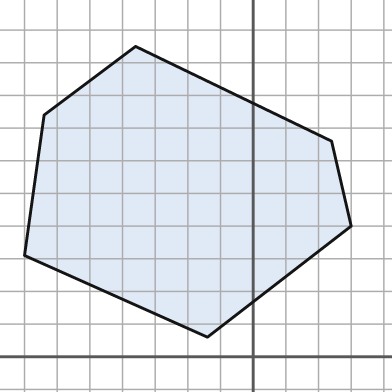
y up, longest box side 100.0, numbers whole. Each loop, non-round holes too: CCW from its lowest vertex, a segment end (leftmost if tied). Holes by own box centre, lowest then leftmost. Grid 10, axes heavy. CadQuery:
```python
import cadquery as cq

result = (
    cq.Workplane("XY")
    .moveTo(-14.0, 6.0)
    .lineTo(30.0, 40.0)
    .lineTo(24.0, 66.0)
    .lineTo(-36.0, 95.0)
    .lineTo(-64.0, 74.0)
    .lineTo(-70.0, 31.0)
    .close()
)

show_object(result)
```